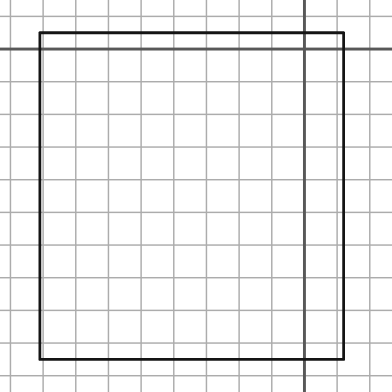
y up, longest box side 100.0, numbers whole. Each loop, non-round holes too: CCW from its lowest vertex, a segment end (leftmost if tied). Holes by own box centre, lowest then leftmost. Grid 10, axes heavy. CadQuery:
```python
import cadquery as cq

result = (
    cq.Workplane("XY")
    .moveTo(-81.0, -95.0)
    .lineTo(12.0, -95.0)
    .lineTo(12.0, 5.0)
    .lineTo(-81.0, 5.0)
    .close()
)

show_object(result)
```